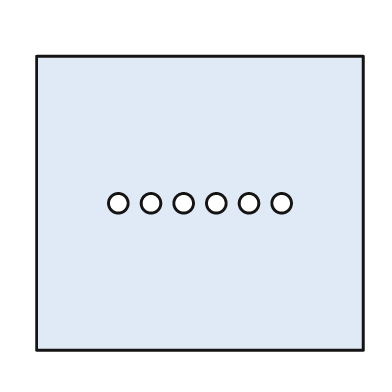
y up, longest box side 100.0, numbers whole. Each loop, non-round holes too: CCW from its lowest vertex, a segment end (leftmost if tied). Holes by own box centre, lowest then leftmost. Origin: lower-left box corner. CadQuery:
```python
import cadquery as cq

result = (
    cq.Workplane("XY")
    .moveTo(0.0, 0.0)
    .lineTo(100.0, 0.0)
    .lineTo(100.0, 90.0)
    .lineTo(0.0, 90.0)
    .close()
    .moveTo(25.0, 45.0)
    .circle(3.0)
    .moveTo(35.0, 45.0)
    .circle(3.0)
    .moveTo(45.0, 45.0)
    .circle(3.0)
    .moveTo(55.0, 45.0)
    .circle(3.0)
    .moveTo(65.0, 45.0)
    .circle(3.0)
    .moveTo(75.0, 45.0)
    .circle(3.0)
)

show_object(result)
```